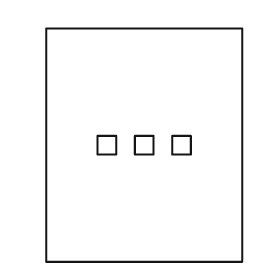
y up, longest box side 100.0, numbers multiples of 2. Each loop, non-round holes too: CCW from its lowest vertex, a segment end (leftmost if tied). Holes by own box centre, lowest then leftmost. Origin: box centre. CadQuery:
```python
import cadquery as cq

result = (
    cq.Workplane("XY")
    .moveTo(-42.0, -50.0)
    .lineTo(42.0, -50.0)
    .lineTo(42.0, 50.0)
    .lineTo(-42.0, 50.0)
    .close()
    .moveTo(-20.0, -4.0)
    .lineTo(-12.0, -4.0)
    .lineTo(-12.0, 4.0)
    .lineTo(-20.0, 4.0)
    .close()
    .moveTo(-4.0, -4.0)
    .lineTo(4.0, -4.0)
    .lineTo(4.0, 4.0)
    .lineTo(-4.0, 4.0)
    .close()
    .moveTo(12.0, -4.0)
    .lineTo(20.0, -4.0)
    .lineTo(20.0, 4.0)
    .lineTo(12.0, 4.0)
    .close()
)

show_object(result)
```